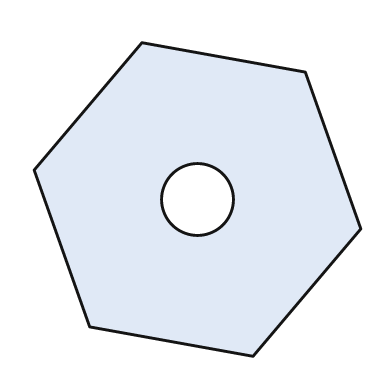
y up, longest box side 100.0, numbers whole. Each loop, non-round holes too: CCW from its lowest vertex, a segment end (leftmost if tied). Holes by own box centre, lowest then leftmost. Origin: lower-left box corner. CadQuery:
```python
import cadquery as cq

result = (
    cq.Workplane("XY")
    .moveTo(67.0, 0.0)
    .lineTo(100.0, 39.0)
    .lineTo(83.0, 87.0)
    .lineTo(33.0, 96.0)
    .lineTo(0.0, 57.0)
    .lineTo(17.0, 9.0)
    .close()
    .moveTo(50.0, 48.0)
    .circle(11.0)
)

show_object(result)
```